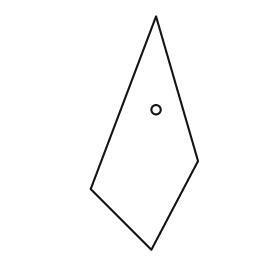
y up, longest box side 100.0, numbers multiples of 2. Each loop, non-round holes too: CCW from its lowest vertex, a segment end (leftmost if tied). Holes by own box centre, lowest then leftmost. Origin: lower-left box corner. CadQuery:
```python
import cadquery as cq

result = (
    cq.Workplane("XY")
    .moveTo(26.0, 0.0)
    .lineTo(46.0, 38.0)
    .lineTo(28.0, 100.0)
    .lineTo(0.0, 26.0)
    .close()
    .moveTo(28.0, 60.0)
    .circle(2.0)
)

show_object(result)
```